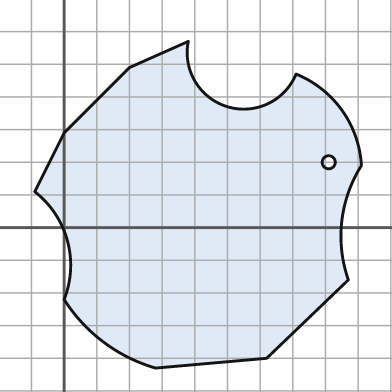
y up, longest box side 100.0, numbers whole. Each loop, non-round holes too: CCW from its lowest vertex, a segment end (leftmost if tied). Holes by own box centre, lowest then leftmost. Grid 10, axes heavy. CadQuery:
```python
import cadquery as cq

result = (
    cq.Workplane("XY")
    .moveTo(28.0, -43.0)
    .lineTo(62.0, -40.0)
    .lineTo(87.0, -16.0)
    .threePointArc((85.0, 2.0), (91.0, 19.0))
    .threePointArc((85.0, 36.0), (71.0, 47.0))
    .threePointArc((50.0, 37.0), (38.0, 57.0))
    .lineTo(20.0, 49.0)
    .lineTo(0.0, 29.0)
    .lineTo(-9.0, 11.0)
    .threePointArc((1.0, -4.0), (0.0, -22.0))
    .threePointArc((12.0, -35.0), (28.0, -43.0))
    .close()
    .moveTo(81.0, 20.0)
    .circle(2.0)
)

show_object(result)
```